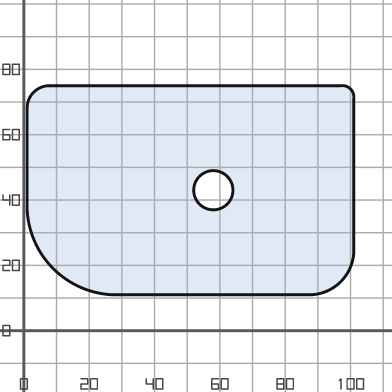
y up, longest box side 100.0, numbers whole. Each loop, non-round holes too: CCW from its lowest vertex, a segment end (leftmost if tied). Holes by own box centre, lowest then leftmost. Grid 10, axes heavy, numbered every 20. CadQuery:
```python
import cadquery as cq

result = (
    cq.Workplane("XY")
    .moveTo(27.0, 11.0)
    .lineTo(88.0, 11.0)
    .threePointArc((97.0, 15.0), (101.0, 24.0))
    .lineTo(101.0, 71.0)
    .threePointArc((100.0, 74.0), (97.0, 75.0))
    .lineTo(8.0, 75.0)
    .threePointArc((3.0, 73.0), (1.0, 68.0))
    .lineTo(1.0, 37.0)
    .threePointArc((9.0, 19.0), (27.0, 11.0))
    .close()
    .moveTo(58.0, 43.0)
    .circle(6.0)
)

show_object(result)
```